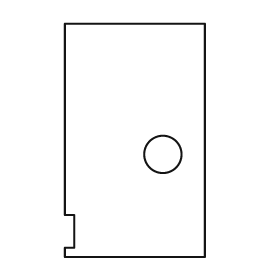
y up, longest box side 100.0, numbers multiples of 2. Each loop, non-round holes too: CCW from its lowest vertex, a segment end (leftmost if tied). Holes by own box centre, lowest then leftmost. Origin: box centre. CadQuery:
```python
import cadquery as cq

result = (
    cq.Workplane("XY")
    .moveTo(-30.0, -50.0)
    .lineTo(30.0, -50.0)
    .lineTo(30.0, 50.0)
    .lineTo(-30.0, 50.0)
    .lineTo(-30.0, -32.0)
    .lineTo(-26.0, -32.0)
    .lineTo(-26.0, -46.0)
    .lineTo(-30.0, -46.0)
    .close()
    .moveTo(12.0, -6.0)
    .circle(8.0)
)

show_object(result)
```